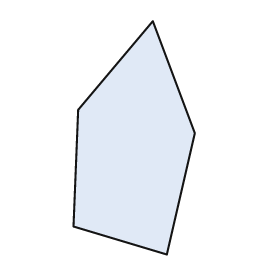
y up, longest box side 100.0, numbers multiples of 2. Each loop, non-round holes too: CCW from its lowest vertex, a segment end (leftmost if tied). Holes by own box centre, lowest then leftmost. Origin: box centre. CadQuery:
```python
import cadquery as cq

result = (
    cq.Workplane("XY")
    .moveTo(14.0, -50.0)
    .lineTo(26.0, 2.0)
    .lineTo(8.0, 50.0)
    .lineTo(-24.0, 12.0)
    .lineTo(-26.0, -38.0)
    .close()
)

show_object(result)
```